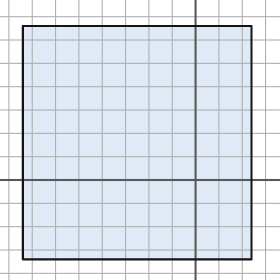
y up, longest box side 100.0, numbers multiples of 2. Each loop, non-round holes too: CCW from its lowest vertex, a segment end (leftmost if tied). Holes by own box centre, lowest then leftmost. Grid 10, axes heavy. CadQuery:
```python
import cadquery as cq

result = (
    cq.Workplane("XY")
    .moveTo(-74.0, -34.0)
    .lineTo(24.0, -34.0)
    .lineTo(24.0, 66.0)
    .lineTo(-74.0, 66.0)
    .close()
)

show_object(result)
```